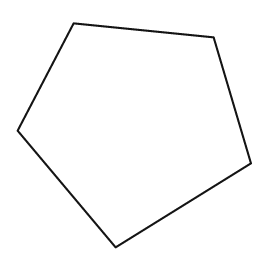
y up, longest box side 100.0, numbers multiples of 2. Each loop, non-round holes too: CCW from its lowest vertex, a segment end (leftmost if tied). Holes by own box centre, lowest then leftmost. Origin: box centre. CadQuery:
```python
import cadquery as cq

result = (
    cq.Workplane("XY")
    .moveTo(-8.0, -48.0)
    .lineTo(50.0, -12.0)
    .lineTo(34.0, 42.0)
    .lineTo(-26.0, 48.0)
    .lineTo(-50.0, 2.0)
    .close()
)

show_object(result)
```